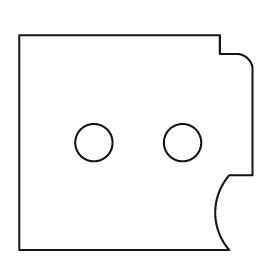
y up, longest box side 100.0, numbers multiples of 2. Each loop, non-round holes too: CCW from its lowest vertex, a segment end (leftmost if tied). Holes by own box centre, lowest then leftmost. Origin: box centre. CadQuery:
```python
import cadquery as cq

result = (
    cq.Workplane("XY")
    .moveTo(-50.0, -46.0)
    .lineTo(40.0, -46.0)
    .threePointArc((34.0, -30.0), (40.0, -14.0))
    .lineTo(50.0, -14.0)
    .lineTo(50.0, 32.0)
    .threePointArc((48.0, 36.0), (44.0, 38.0))
    .lineTo(36.0, 38.0)
    .lineTo(36.0, 46.0)
    .lineTo(-50.0, 46.0)
    .close()
    .moveTo(-18.0, 0.0)
    .circle(8.0)
    .moveTo(20.0, 0.0)
    .circle(8.0)
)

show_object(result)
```